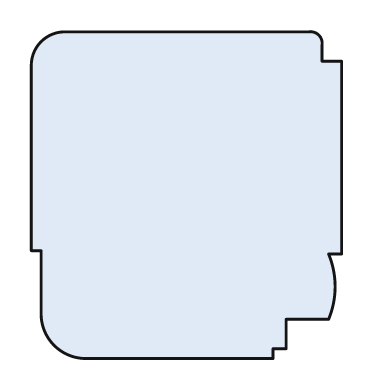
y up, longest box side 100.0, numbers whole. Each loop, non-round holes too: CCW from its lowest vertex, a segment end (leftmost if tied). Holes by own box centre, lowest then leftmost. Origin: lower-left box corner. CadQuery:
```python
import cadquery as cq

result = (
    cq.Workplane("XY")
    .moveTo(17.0, 0.0)
    .lineTo(74.0, 0.0)
    .lineTo(74.0, 3.0)
    .lineTo(78.0, 3.0)
    .lineTo(78.0, 12.0)
    .lineTo(91.0, 12.0)
    .threePointArc((93.0, 22.0), (91.0, 32.0))
    .lineTo(95.0, 32.0)
    .lineTo(95.0, 91.0)
    .lineTo(89.0, 91.0)
    .lineTo(89.0, 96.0)
    .threePointArc((88.0, 99.0), (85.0, 100.0))
    .lineTo(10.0, 100.0)
    .threePointArc((3.0, 97.0), (0.0, 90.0))
    .lineTo(0.0, 33.0)
    .lineTo(3.0, 33.0)
    .lineTo(3.0, 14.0)
    .threePointArc((7.0, 4.0), (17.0, 0.0))
    .close()
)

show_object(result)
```